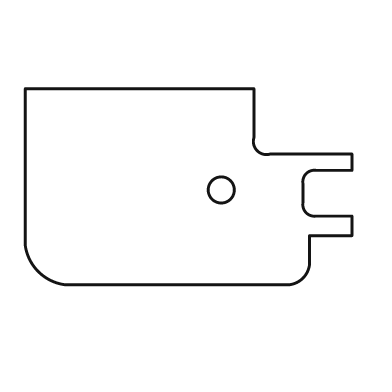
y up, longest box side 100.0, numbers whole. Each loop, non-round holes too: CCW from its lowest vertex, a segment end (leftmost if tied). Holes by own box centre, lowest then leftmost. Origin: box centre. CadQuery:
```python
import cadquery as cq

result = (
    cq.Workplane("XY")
    .moveTo(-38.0, -30.0)
    .lineTo(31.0, -30.0)
    .threePointArc((35.0, -28.0), (37.0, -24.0))
    .lineTo(37.0, -15.0)
    .lineTo(50.0, -15.0)
    .lineTo(50.0, -9.0)
    .lineTo(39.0, -9.0)
    .threePointArc((36.0, -8.0), (35.0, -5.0))
    .lineTo(35.0, 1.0)
    .threePointArc((36.0, 4.0), (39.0, 5.0))
    .lineTo(50.0, 5.0)
    .lineTo(50.0, 10.0)
    .lineTo(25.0, 10.0)
    .threePointArc((21.0, 11.0), (20.0, 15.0))
    .lineTo(20.0, 30.0)
    .lineTo(-50.0, 30.0)
    .lineTo(-50.0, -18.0)
    .threePointArc((-46.0, -26.0), (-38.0, -30.0))
    .close()
    .moveTo(10.0, -1.0)
    .circle(4.0)
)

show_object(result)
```